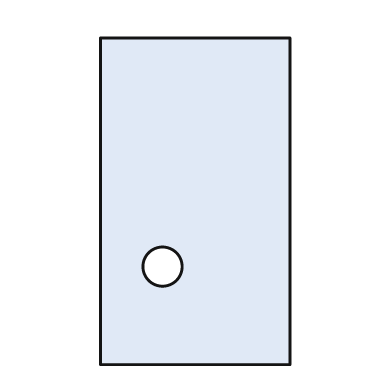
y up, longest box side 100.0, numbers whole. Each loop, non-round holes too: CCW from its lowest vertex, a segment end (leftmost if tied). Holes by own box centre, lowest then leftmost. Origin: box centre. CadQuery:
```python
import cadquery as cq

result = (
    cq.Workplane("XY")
    .moveTo(-29.0, -50.0)
    .lineTo(29.0, -50.0)
    .lineTo(29.0, 50.0)
    .lineTo(-29.0, 50.0)
    .close()
    .moveTo(-10.0, -20.0)
    .circle(6.0)
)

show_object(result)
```